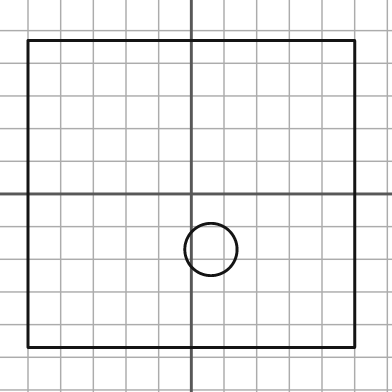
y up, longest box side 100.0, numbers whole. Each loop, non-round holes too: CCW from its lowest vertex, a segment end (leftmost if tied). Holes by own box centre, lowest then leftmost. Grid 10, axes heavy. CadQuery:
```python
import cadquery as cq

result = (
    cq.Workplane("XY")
    .moveTo(-50.0, -47.0)
    .lineTo(50.0, -47.0)
    .lineTo(50.0, 47.0)
    .lineTo(-50.0, 47.0)
    .close()
    .moveTo(6.0, -17.0)
    .circle(8.0)
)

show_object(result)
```